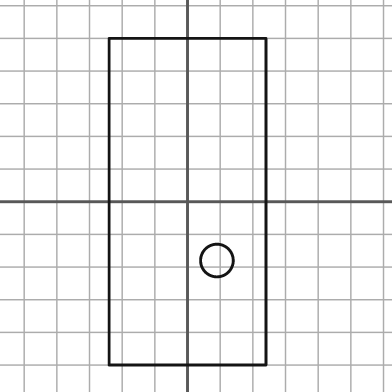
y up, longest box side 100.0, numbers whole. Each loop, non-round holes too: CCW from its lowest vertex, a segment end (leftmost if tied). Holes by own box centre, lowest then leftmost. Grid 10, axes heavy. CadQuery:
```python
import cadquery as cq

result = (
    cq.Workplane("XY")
    .moveTo(-24.0, -50.0)
    .lineTo(24.0, -50.0)
    .lineTo(24.0, 50.0)
    .lineTo(-24.0, 50.0)
    .close()
    .moveTo(9.0, -18.0)
    .circle(5.0)
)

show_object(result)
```